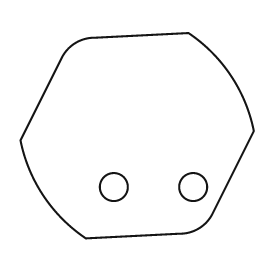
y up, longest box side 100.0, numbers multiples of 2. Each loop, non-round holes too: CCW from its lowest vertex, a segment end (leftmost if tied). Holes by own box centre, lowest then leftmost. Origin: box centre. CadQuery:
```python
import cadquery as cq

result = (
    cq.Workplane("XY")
    .moveTo(-22.0, -44.0)
    .lineTo(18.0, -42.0)
    .threePointArc((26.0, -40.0), (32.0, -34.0))
    .lineTo(50.0, 2.0)
    .threePointArc((40.0, 26.0), (22.0, 44.0))
    .lineTo(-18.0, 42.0)
    .threePointArc((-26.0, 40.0), (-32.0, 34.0))
    .lineTo(-50.0, -2.0)
    .threePointArc((-40.0, -26.0), (-22.0, -44.0))
    .close()
    .moveTo(-10.0, -22.0)
    .circle(6.0)
    .moveTo(24.0, -22.0)
    .circle(6.0)
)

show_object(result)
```